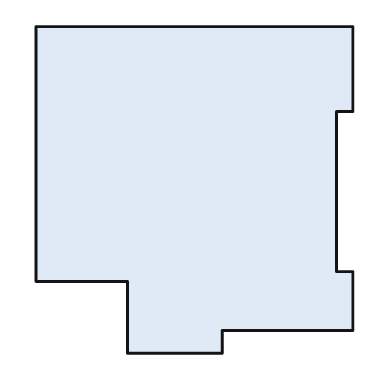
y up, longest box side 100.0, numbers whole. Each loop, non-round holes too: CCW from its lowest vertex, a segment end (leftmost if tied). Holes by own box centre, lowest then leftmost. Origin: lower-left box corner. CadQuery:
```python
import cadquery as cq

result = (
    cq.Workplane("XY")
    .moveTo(28.0, 0.0)
    .lineTo(57.0, 0.0)
    .lineTo(57.0, 7.0)
    .lineTo(97.0, 7.0)
    .lineTo(97.0, 25.0)
    .lineTo(92.0, 25.0)
    .lineTo(92.0, 74.0)
    .lineTo(97.0, 74.0)
    .lineTo(97.0, 100.0)
    .lineTo(0.0, 100.0)
    .lineTo(0.0, 22.0)
    .lineTo(28.0, 22.0)
    .close()
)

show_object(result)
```